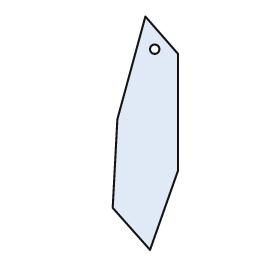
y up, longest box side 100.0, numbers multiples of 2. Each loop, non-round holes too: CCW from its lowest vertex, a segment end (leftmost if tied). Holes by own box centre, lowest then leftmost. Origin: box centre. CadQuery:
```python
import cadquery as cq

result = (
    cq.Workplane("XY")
    .moveTo(2.0, -50.0)
    .lineTo(14.0, -16.0)
    .lineTo(14.0, 34.0)
    .lineTo(0.0, 50.0)
    .lineTo(-12.0, 6.0)
    .lineTo(-14.0, -32.0)
    .close()
    .moveTo(4.0, 36.0)
    .circle(2.0)
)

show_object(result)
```